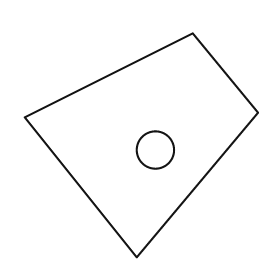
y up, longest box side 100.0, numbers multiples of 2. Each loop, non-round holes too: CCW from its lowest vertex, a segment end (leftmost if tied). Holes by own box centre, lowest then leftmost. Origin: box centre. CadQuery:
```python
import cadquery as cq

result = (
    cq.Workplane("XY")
    .moveTo(-2.0, -48.0)
    .lineTo(50.0, 14.0)
    .lineTo(22.0, 48.0)
    .lineTo(-50.0, 12.0)
    .close()
    .moveTo(6.0, -2.0)
    .circle(8.0)
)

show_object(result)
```